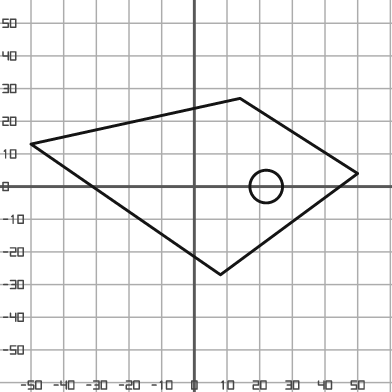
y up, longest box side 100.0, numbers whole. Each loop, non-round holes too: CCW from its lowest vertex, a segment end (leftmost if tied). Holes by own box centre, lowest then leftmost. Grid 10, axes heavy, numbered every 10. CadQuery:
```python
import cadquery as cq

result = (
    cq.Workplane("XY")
    .moveTo(8.0, -27.0)
    .lineTo(50.0, 4.0)
    .lineTo(14.0, 27.0)
    .lineTo(-50.0, 13.0)
    .close()
    .moveTo(22.0, 0.0)
    .circle(5.0)
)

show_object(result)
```